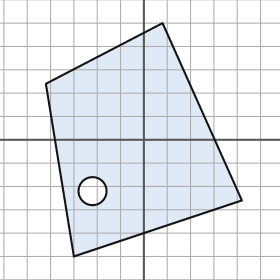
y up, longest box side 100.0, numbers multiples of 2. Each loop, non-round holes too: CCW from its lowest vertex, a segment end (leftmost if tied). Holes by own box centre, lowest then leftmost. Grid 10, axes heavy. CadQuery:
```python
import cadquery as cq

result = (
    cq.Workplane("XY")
    .moveTo(-30.0, -50.0)
    .lineTo(42.0, -26.0)
    .lineTo(8.0, 50.0)
    .lineTo(-42.0, 24.0)
    .close()
    .moveTo(-22.0, -22.0)
    .circle(6.0)
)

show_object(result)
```